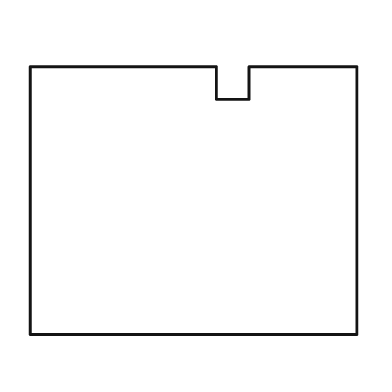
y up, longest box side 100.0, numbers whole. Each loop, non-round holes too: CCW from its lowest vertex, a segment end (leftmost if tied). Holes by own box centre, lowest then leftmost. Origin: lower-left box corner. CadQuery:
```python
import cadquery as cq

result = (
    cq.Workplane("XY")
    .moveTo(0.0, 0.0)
    .lineTo(100.0, 0.0)
    .lineTo(100.0, 82.0)
    .lineTo(67.0, 82.0)
    .lineTo(67.0, 72.0)
    .lineTo(57.0, 72.0)
    .lineTo(57.0, 82.0)
    .lineTo(0.0, 82.0)
    .close()
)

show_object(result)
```